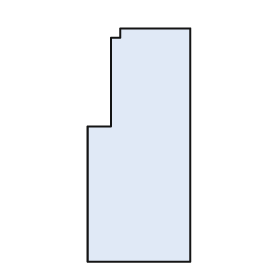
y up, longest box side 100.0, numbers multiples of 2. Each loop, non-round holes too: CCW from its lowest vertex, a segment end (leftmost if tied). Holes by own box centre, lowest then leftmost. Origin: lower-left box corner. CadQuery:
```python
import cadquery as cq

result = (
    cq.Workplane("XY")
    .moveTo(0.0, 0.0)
    .lineTo(44.0, 0.0)
    .lineTo(44.0, 100.0)
    .lineTo(14.0, 100.0)
    .lineTo(14.0, 96.0)
    .lineTo(10.0, 96.0)
    .lineTo(10.0, 58.0)
    .lineTo(0.0, 58.0)
    .close()
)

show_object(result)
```